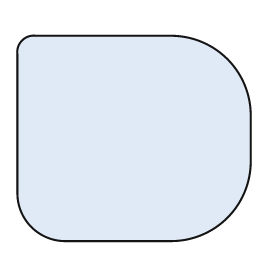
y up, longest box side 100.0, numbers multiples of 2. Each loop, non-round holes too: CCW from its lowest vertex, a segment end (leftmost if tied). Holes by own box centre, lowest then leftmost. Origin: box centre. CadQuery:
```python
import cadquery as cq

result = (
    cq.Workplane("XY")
    .moveTo(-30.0, -44.0)
    .lineTo(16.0, -44.0)
    .threePointArc((40.0, -34.0), (50.0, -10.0))
    .lineTo(50.0, 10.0)
    .threePointArc((40.0, 34.0), (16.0, 44.0))
    .lineTo(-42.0, 44.0)
    .threePointArc((-48.0, 42.0), (-50.0, 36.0))
    .lineTo(-50.0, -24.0)
    .threePointArc((-44.0, -38.0), (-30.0, -44.0))
    .close()
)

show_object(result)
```